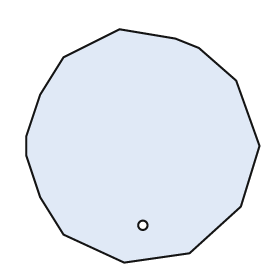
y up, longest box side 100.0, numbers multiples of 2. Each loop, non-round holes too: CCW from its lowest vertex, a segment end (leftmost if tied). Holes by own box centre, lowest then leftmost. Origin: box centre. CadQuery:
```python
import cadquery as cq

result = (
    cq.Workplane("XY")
    .moveTo(-8.0, -50.0)
    .lineTo(20.0, -46.0)
    .lineTo(42.0, -26.0)
    .lineTo(50.0, 0.0)
    .lineTo(40.0, 28.0)
    .lineTo(24.0, 42.0)
    .lineTo(14.0, 46.0)
    .lineTo(-10.0, 50.0)
    .lineTo(-34.0, 38.0)
    .lineTo(-44.0, 22.0)
    .lineTo(-50.0, 4.0)
    .lineTo(-50.0, -4.0)
    .lineTo(-44.0, -22.0)
    .lineTo(-34.0, -38.0)
    .close()
    .moveTo(0.0, -34.0)
    .circle(2.0)
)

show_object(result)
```